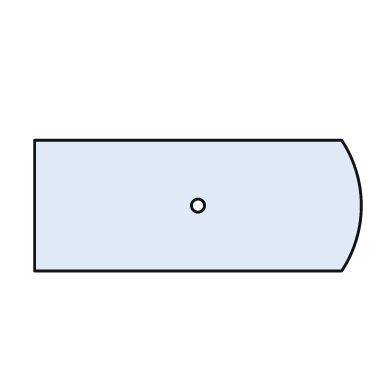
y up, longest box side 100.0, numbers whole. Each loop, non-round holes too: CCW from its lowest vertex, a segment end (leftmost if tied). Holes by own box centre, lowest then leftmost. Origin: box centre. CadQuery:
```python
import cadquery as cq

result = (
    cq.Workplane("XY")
    .moveTo(-50.0, -20.0)
    .lineTo(44.0, -20.0)
    .threePointArc((50.0, 0.0), (44.0, 20.0))
    .lineTo(-50.0, 20.0)
    .close()
    .moveTo(0.0, 0.0)
    .circle(2.0)
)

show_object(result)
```